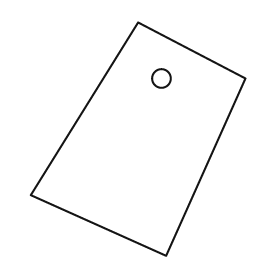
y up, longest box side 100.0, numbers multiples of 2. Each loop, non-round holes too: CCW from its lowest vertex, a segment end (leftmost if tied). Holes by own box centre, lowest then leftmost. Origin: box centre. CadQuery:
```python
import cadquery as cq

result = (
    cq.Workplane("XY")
    .moveTo(12.0, -50.0)
    .lineTo(46.0, 26.0)
    .lineTo(0.0, 50.0)
    .lineTo(-46.0, -24.0)
    .close()
    .moveTo(10.0, 26.0)
    .circle(4.0)
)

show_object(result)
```